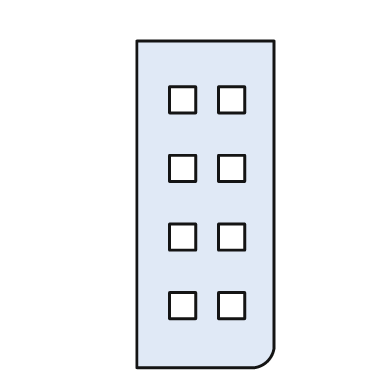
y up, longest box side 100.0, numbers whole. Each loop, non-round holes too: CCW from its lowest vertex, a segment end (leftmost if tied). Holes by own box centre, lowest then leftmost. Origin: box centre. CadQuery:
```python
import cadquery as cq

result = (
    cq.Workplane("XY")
    .moveTo(-21.0, -50.0)
    .lineTo(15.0, -50.0)
    .threePointArc((19.0, -48.0), (21.0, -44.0))
    .lineTo(21.0, 50.0)
    .lineTo(-21.0, 50.0)
    .close()
    .moveTo(-11.0, -35.0)
    .lineTo(-3.0, -35.0)
    .lineTo(-3.0, -27.0)
    .lineTo(-11.0, -27.0)
    .close()
    .moveTo(4.0, -35.0)
    .lineTo(12.0, -35.0)
    .lineTo(12.0, -27.0)
    .lineTo(4.0, -27.0)
    .close()
    .moveTo(-11.0, -14.0)
    .lineTo(-3.0, -14.0)
    .lineTo(-3.0, -6.0)
    .lineTo(-11.0, -6.0)
    .close()
    .moveTo(4.0, -14.0)
    .lineTo(12.0, -14.0)
    .lineTo(12.0, -6.0)
    .lineTo(4.0, -6.0)
    .close()
    .moveTo(-11.0, 7.0)
    .lineTo(-3.0, 7.0)
    .lineTo(-3.0, 15.0)
    .lineTo(-11.0, 15.0)
    .close()
    .moveTo(4.0, 7.0)
    .lineTo(12.0, 7.0)
    .lineTo(12.0, 15.0)
    .lineTo(4.0, 15.0)
    .close()
    .moveTo(-11.0, 28.0)
    .lineTo(-3.0, 28.0)
    .lineTo(-3.0, 36.0)
    .lineTo(-11.0, 36.0)
    .close()
    .moveTo(4.0, 28.0)
    .lineTo(12.0, 28.0)
    .lineTo(12.0, 36.0)
    .lineTo(4.0, 36.0)
    .close()
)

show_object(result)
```